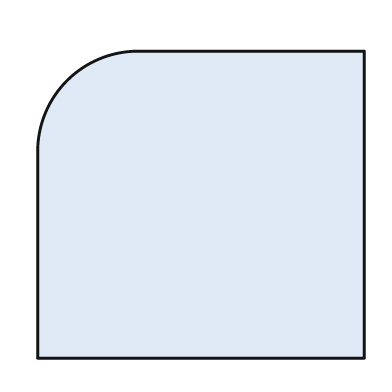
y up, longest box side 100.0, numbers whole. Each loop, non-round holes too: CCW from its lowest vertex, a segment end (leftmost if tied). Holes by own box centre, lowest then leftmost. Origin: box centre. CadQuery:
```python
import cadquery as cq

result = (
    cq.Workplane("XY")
    .moveTo(-50.0, -47.0)
    .lineTo(50.0, -47.0)
    .lineTo(50.0, 47.0)
    .lineTo(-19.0, 47.0)
    .threePointArc((-41.0, 38.0), (-50.0, 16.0))
    .close()
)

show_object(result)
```